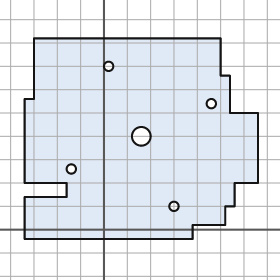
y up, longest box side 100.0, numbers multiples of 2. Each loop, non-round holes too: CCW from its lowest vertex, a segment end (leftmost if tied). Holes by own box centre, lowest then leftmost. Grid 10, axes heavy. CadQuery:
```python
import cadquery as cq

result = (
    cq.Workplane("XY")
    .moveTo(-34.0, -4.0)
    .lineTo(38.0, -4.0)
    .lineTo(38.0, 2.0)
    .lineTo(52.0, 2.0)
    .lineTo(52.0, 10.0)
    .lineTo(56.0, 10.0)
    .lineTo(56.0, 20.0)
    .lineTo(66.0, 20.0)
    .lineTo(66.0, 50.0)
    .lineTo(54.0, 50.0)
    .lineTo(54.0, 66.0)
    .lineTo(50.0, 66.0)
    .lineTo(50.0, 82.0)
    .lineTo(-30.0, 82.0)
    .lineTo(-30.0, 56.0)
    .lineTo(-34.0, 56.0)
    .lineTo(-34.0, 20.0)
    .lineTo(-16.0, 20.0)
    .lineTo(-16.0, 14.0)
    .lineTo(-34.0, 14.0)
    .close()
    .moveTo(30.0, 10.0)
    .circle(2.0)
    .moveTo(-14.0, 26.0)
    .circle(2.0)
    .moveTo(16.0, 40.0)
    .circle(4.0)
    .moveTo(46.0, 54.0)
    .circle(2.0)
    .moveTo(2.0, 70.0)
    .circle(2.0)
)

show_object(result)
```